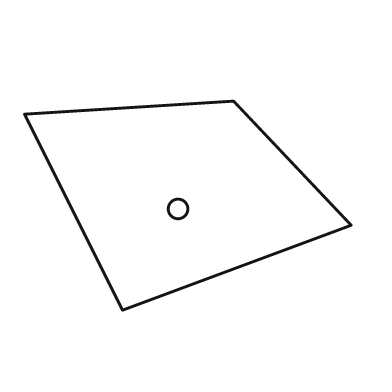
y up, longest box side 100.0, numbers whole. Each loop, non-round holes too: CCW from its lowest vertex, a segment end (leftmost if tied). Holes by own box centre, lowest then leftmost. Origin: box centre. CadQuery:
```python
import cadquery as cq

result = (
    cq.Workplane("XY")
    .moveTo(-20.0, -32.0)
    .lineTo(50.0, -6.0)
    .lineTo(14.0, 32.0)
    .lineTo(-50.0, 28.0)
    .close()
    .moveTo(-3.0, -1.0)
    .circle(3.0)
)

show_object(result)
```